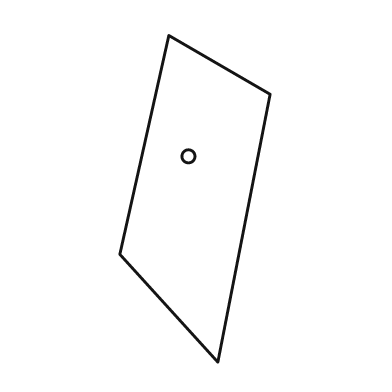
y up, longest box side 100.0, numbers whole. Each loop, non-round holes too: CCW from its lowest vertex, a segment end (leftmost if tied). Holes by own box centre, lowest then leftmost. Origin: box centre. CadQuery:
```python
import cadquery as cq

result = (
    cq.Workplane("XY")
    .moveTo(7.0, -50.0)
    .lineTo(23.0, 32.0)
    .lineTo(-8.0, 50.0)
    .lineTo(-23.0, -17.0)
    .close()
    .moveTo(-2.0, 13.0)
    .circle(2.0)
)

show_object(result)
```